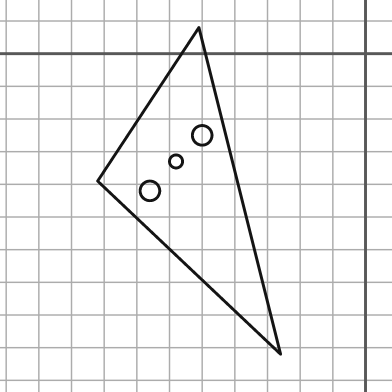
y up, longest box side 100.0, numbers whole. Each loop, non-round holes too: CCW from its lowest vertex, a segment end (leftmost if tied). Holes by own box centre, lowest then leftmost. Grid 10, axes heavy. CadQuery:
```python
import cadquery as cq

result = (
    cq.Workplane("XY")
    .moveTo(-26.0, -92.0)
    .lineTo(-51.0, 8.0)
    .lineTo(-82.0, -39.0)
    .close()
    .moveTo(-66.0, -42.0)
    .circle(3.0)
    .moveTo(-58.0, -33.0)
    .circle(2.0)
    .moveTo(-50.0, -25.0)
    .circle(3.0)
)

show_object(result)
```